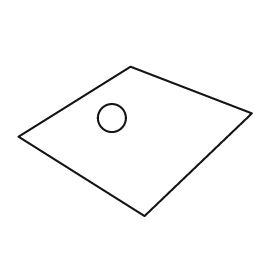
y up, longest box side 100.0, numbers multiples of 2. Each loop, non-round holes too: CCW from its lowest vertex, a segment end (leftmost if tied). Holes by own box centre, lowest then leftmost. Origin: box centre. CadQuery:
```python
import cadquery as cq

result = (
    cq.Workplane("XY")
    .moveTo(4.0, -32.0)
    .lineTo(50.0, 12.0)
    .lineTo(-2.0, 32.0)
    .lineTo(-50.0, 2.0)
    .close()
    .moveTo(-10.0, 10.0)
    .circle(6.0)
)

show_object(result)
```